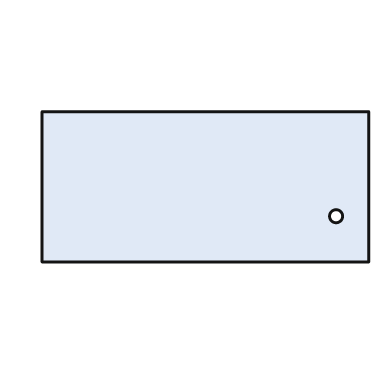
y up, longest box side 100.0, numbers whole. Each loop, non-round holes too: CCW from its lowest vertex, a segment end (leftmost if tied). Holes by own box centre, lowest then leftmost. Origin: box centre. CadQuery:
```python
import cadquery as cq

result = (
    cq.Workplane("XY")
    .moveTo(-50.0, -23.0)
    .lineTo(50.0, -23.0)
    .lineTo(50.0, 23.0)
    .lineTo(-50.0, 23.0)
    .close()
    .moveTo(40.0, -9.0)
    .circle(2.0)
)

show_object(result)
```